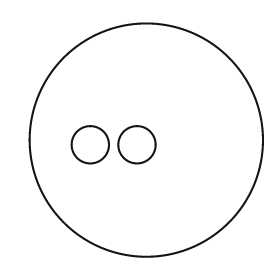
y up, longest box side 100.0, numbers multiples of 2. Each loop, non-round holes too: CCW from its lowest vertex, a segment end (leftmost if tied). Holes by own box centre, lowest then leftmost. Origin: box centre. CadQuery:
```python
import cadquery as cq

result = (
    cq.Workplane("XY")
    .moveTo(0.0, 0.0)
    .circle(50.0)
    .moveTo(-24.0, -2.0)
    .circle(8.0)
    .moveTo(-4.0, -2.0)
    .circle(8.0)
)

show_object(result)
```